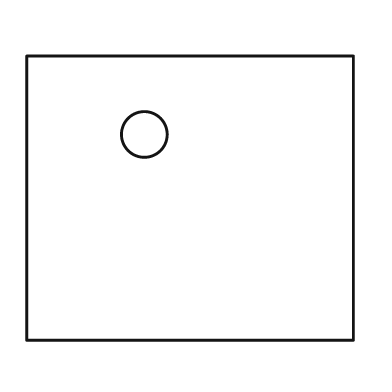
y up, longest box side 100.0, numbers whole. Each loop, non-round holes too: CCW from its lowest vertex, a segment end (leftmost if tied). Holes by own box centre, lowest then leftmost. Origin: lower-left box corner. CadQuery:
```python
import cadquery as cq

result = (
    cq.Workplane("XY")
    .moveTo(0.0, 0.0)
    .lineTo(100.0, 0.0)
    .lineTo(100.0, 87.0)
    .lineTo(0.0, 87.0)
    .close()
    .moveTo(36.0, 63.0)
    .circle(7.0)
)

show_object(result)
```